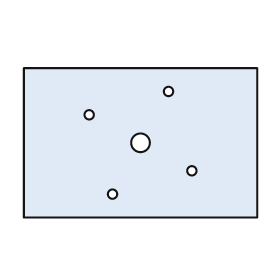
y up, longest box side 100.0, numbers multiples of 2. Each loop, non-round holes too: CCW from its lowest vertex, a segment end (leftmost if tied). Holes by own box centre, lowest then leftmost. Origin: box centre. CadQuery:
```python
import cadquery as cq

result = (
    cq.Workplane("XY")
    .moveTo(-50.0, -32.0)
    .lineTo(50.0, -32.0)
    .lineTo(50.0, 32.0)
    .lineTo(-50.0, 32.0)
    .close()
    .moveTo(-12.0, -22.0)
    .circle(2.0)
    .moveTo(22.0, -12.0)
    .circle(2.0)
    .moveTo(0.0, 0.0)
    .circle(4.0)
    .moveTo(-22.0, 12.0)
    .circle(2.0)
    .moveTo(12.0, 22.0)
    .circle(2.0)
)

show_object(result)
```